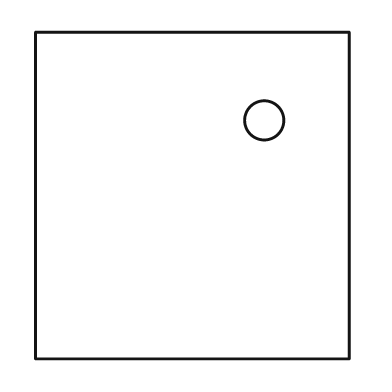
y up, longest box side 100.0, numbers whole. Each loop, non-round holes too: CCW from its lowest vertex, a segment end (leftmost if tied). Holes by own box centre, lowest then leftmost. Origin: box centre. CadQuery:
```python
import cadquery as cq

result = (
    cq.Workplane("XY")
    .moveTo(-48.0, -50.0)
    .lineTo(48.0, -50.0)
    .lineTo(48.0, 50.0)
    .lineTo(-48.0, 50.0)
    .close()
    .moveTo(22.0, 23.0)
    .circle(6.0)
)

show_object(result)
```